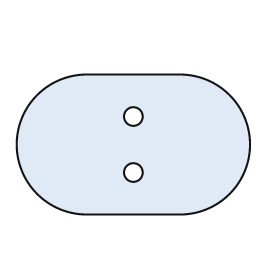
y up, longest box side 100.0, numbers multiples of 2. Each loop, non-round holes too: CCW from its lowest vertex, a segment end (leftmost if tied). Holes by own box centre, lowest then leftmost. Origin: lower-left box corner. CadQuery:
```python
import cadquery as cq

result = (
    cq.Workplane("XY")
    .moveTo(30.0, 0.0)
    .lineTo(70.0, 0.0)
    .threePointArc((100.0, 30.0), (70.0, 60.0))
    .lineTo(30.0, 60.0)
    .threePointArc((0.0, 30.0), (30.0, 0.0))
    .close()
    .moveTo(50.0, 18.0)
    .circle(4.0)
    .moveTo(50.0, 42.0)
    .circle(4.0)
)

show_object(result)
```